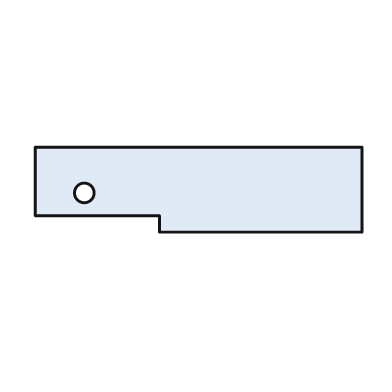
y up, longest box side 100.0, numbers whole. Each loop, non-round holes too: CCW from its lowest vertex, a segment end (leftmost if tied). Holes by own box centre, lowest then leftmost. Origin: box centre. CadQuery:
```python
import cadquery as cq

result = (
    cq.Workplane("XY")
    .moveTo(-12.0, -13.0)
    .lineTo(50.0, -13.0)
    .lineTo(50.0, 13.0)
    .lineTo(-50.0, 13.0)
    .lineTo(-50.0, -8.0)
    .lineTo(-12.0, -8.0)
    .close()
    .moveTo(-35.0, -1.0)
    .circle(3.0)
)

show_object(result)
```